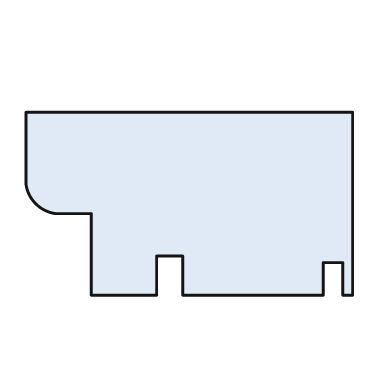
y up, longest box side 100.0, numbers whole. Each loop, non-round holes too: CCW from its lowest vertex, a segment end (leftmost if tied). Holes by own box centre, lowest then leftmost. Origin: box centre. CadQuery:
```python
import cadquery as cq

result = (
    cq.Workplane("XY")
    .moveTo(-30.0, -28.0)
    .lineTo(-10.0, -28.0)
    .lineTo(-10.0, -16.0)
    .lineTo(-2.0, -16.0)
    .lineTo(-2.0, -28.0)
    .lineTo(41.0, -28.0)
    .lineTo(41.0, -18.0)
    .lineTo(47.0, -18.0)
    .lineTo(47.0, -28.0)
    .lineTo(50.0, -28.0)
    .lineTo(50.0, 28.0)
    .lineTo(-50.0, 28.0)
    .lineTo(-50.0, 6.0)
    .threePointArc((-47.0, 0.0), (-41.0, -3.0))
    .lineTo(-30.0, -3.0)
    .close()
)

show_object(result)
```